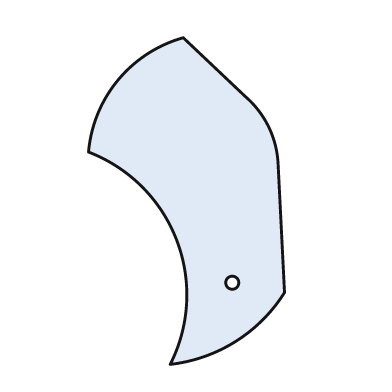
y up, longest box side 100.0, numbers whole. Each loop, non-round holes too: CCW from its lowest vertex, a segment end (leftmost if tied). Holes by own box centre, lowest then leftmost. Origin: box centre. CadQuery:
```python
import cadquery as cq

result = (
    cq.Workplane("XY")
    .moveTo(-5.0, -50.0)
    .threePointArc((15.0, -43.0), (30.0, -28.0))
    .lineTo(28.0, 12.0)
    .threePointArc((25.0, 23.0), (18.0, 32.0))
    .lineTo(-1.0, 50.0)
    .threePointArc((-21.0, 37.0), (-30.0, 15.0))
    .threePointArc((-3.0, -12.0), (-5.0, -50.0))
    .close()
    .moveTo(14.0, -25.0)
    .circle(2.0)
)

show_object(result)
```